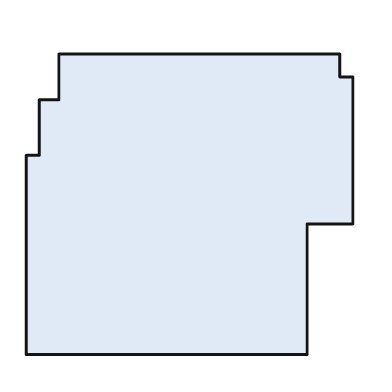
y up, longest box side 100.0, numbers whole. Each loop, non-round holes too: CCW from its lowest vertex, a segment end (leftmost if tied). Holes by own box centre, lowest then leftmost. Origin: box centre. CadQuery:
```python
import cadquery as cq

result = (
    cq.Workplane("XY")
    .moveTo(-50.0, -46.0)
    .lineTo(36.0, -46.0)
    .lineTo(36.0, -6.0)
    .lineTo(50.0, -6.0)
    .lineTo(50.0, 39.0)
    .lineTo(46.0, 39.0)
    .lineTo(46.0, 46.0)
    .lineTo(-40.0, 46.0)
    .lineTo(-40.0, 32.0)
    .lineTo(-46.0, 32.0)
    .lineTo(-46.0, 15.0)
    .lineTo(-50.0, 15.0)
    .close()
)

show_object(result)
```